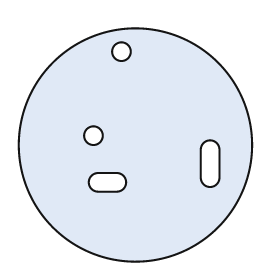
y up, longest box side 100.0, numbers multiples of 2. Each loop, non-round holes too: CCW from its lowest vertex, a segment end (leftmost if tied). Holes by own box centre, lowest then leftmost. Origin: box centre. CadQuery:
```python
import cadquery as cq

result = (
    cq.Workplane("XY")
    .moveTo(0.0, 0.0)
    .circle(50.0)
    .moveTo(-16.0, -20.0)
    .lineTo(-8.0, -20.0)
    .threePointArc((-4.0, -16.0), (-8.0, -12.0))
    .lineTo(-16.0, -12.0)
    .threePointArc((-20.0, -16.0), (-16.0, -20.0))
    .close()
    .moveTo(28.0, -14.0)
    .threePointArc((32.0, -18.0), (36.0, -14.0))
    .lineTo(36.0, -2.0)
    .threePointArc((32.0, 2.0), (28.0, -2.0))
    .close()
    .moveTo(-18.0, 4.0)
    .circle(4.0)
    .moveTo(-6.0, 40.0)
    .circle(4.0)
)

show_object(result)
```